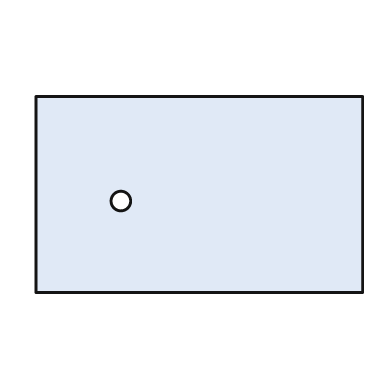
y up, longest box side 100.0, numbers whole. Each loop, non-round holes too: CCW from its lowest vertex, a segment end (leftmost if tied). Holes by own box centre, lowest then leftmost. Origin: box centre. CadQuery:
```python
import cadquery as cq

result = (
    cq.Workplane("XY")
    .moveTo(-50.0, -30.0)
    .lineTo(50.0, -30.0)
    .lineTo(50.0, 30.0)
    .lineTo(-50.0, 30.0)
    .close()
    .moveTo(-24.0, -2.0)
    .circle(3.0)
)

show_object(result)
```